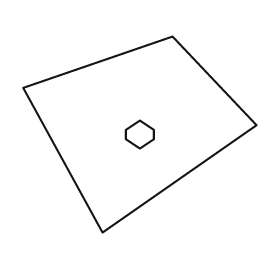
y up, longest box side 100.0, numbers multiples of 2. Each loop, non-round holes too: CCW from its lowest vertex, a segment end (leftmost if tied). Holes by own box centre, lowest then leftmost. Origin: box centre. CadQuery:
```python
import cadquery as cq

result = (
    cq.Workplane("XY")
    .moveTo(-16.0, -42.0)
    .lineTo(50.0, 4.0)
    .lineTo(14.0, 42.0)
    .lineTo(-50.0, 20.0)
    .close()
    .moveTo(0.0, -6.0)
    .lineTo(6.0, -2.0)
    .lineTo(6.0, 2.0)
    .lineTo(0.0, 6.0)
    .lineTo(-6.0, 2.0)
    .lineTo(-6.0, -2.0)
    .close()
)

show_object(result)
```